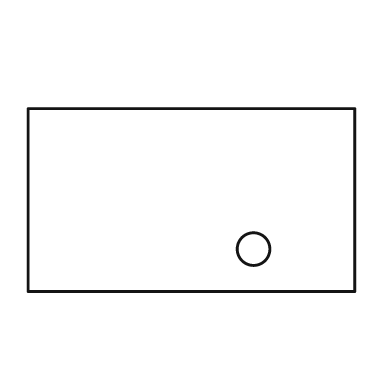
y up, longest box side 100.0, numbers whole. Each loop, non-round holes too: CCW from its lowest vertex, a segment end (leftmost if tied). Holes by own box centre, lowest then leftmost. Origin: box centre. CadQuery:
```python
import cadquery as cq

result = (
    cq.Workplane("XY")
    .moveTo(-50.0, -28.0)
    .lineTo(50.0, -28.0)
    .lineTo(50.0, 28.0)
    .lineTo(-50.0, 28.0)
    .close()
    .moveTo(19.0, -15.0)
    .circle(5.0)
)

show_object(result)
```